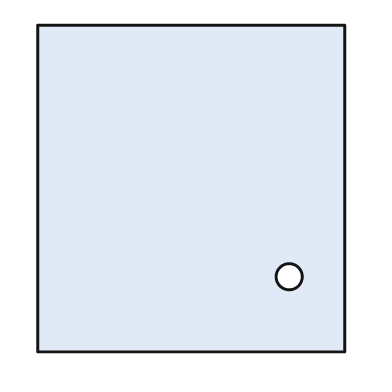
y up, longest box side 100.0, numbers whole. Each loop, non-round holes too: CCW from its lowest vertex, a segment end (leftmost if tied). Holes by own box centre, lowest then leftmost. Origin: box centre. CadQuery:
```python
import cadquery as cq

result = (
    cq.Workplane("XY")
    .moveTo(-47.0, -50.0)
    .lineTo(47.0, -50.0)
    .lineTo(47.0, 50.0)
    .lineTo(-47.0, 50.0)
    .close()
    .moveTo(30.0, -27.0)
    .circle(4.0)
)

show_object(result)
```